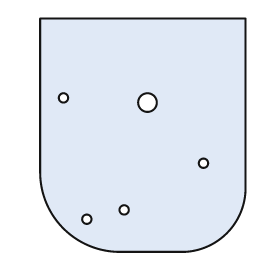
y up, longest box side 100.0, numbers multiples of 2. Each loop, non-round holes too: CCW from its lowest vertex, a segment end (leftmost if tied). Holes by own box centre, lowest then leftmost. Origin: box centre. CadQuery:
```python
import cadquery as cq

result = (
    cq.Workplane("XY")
    .moveTo(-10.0, -50.0)
    .lineTo(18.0, -50.0)
    .threePointArc((36.0, -42.0), (44.0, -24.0))
    .lineTo(44.0, 50.0)
    .lineTo(-44.0, 50.0)
    .lineTo(-44.0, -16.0)
    .threePointArc((-34.0, -40.0), (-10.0, -50.0))
    .close()
    .moveTo(-24.0, -36.0)
    .circle(2.0)
    .moveTo(-8.0, -32.0)
    .circle(2.0)
    .moveTo(26.0, -12.0)
    .circle(2.0)
    .moveTo(2.0, 14.0)
    .circle(4.0)
    .moveTo(-34.0, 16.0)
    .circle(2.0)
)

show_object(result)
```